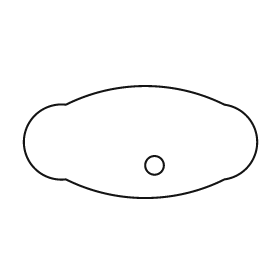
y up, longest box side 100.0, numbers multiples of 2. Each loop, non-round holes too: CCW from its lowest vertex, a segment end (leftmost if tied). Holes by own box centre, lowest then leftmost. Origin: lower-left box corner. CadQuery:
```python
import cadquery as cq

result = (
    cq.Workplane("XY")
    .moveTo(18.0, 8.0)
    .threePointArc((52.0, 0.0), (86.0, 8.0))
    .threePointArc((100.0, 24.0), (86.0, 40.0))
    .threePointArc((52.0, 48.0), (18.0, 40.0))
    .threePointArc((0.0, 24.0), (18.0, 8.0))
    .close()
    .moveTo(56.0, 14.0)
    .circle(4.0)
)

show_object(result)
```